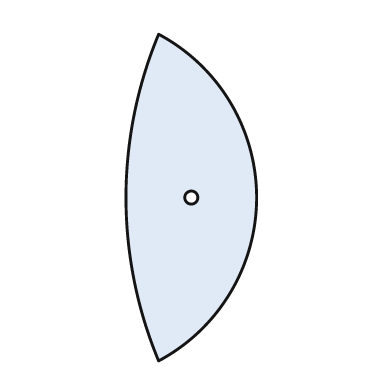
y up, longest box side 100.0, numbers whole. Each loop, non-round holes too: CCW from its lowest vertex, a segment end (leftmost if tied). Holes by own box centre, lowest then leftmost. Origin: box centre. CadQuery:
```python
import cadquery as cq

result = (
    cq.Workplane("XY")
    .moveTo(-10.0, -50.0)
    .threePointArc((20.0, 0.0), (-10.0, 50.0))
    .threePointArc((-20.0, 0.0), (-10.0, -50.0))
    .close()
    .moveTo(0.0, 0.0)
    .circle(2.0)
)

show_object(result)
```